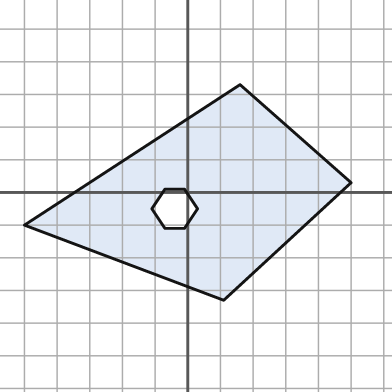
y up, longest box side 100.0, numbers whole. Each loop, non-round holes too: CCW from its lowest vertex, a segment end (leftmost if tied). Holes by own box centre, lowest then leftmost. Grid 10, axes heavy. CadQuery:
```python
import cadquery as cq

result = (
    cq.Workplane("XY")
    .moveTo(11.0, -33.0)
    .lineTo(50.0, 3.0)
    .lineTo(16.0, 33.0)
    .lineTo(-50.0, -10.0)
    .close()
    .moveTo(-7.0, -11.0)
    .lineTo(-1.0, -11.0)
    .lineTo(3.0, -5.0)
    .lineTo(-1.0, 1.0)
    .lineTo(-7.0, 1.0)
    .lineTo(-11.0, -5.0)
    .close()
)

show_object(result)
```